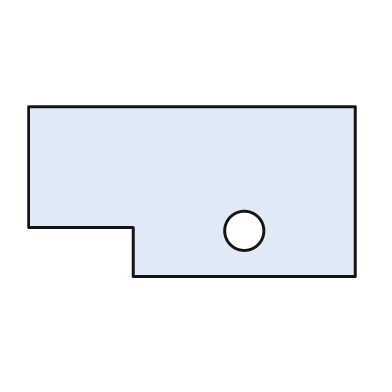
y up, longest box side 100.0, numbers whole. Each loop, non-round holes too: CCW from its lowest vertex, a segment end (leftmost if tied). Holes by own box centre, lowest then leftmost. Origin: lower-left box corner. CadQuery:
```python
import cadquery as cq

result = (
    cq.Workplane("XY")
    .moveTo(32.0, 0.0)
    .lineTo(100.0, 0.0)
    .lineTo(100.0, 52.0)
    .lineTo(0.0, 52.0)
    .lineTo(0.0, 15.0)
    .lineTo(32.0, 15.0)
    .close()
    .moveTo(66.0, 14.0)
    .circle(6.0)
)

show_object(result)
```